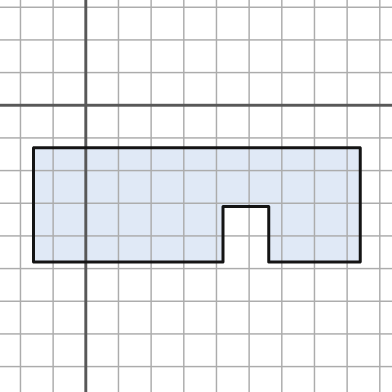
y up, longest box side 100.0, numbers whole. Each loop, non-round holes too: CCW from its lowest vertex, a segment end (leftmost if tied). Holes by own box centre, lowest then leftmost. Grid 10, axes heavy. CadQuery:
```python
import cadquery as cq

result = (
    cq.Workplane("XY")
    .moveTo(-16.0, -48.0)
    .lineTo(42.0, -48.0)
    .lineTo(42.0, -31.0)
    .lineTo(56.0, -31.0)
    .lineTo(56.0, -48.0)
    .lineTo(84.0, -48.0)
    .lineTo(84.0, -13.0)
    .lineTo(-16.0, -13.0)
    .close()
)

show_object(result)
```